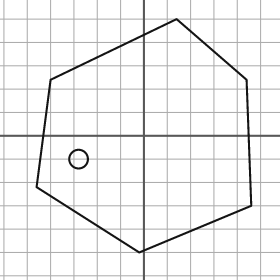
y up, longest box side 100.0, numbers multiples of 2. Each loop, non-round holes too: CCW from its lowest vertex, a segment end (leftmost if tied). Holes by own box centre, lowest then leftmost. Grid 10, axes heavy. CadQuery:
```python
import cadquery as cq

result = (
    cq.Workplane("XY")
    .moveTo(-2.0, -50.0)
    .lineTo(46.0, -30.0)
    .lineTo(44.0, 24.0)
    .lineTo(14.0, 50.0)
    .lineTo(-40.0, 24.0)
    .lineTo(-46.0, -22.0)
    .close()
    .moveTo(-28.0, -10.0)
    .circle(4.0)
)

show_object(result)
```